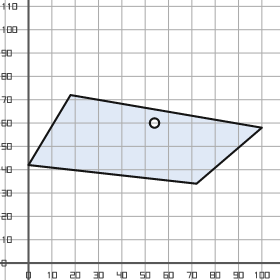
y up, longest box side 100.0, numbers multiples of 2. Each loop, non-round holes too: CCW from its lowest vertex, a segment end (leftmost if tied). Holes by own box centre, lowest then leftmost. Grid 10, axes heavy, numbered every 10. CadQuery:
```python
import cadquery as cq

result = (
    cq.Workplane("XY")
    .moveTo(72.0, 34.0)
    .lineTo(100.0, 58.0)
    .lineTo(18.0, 72.0)
    .lineTo(0.0, 42.0)
    .close()
    .moveTo(54.0, 60.0)
    .circle(2.0)
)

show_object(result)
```